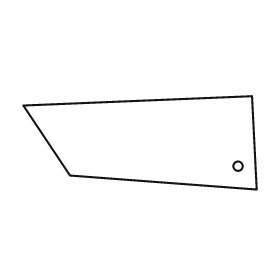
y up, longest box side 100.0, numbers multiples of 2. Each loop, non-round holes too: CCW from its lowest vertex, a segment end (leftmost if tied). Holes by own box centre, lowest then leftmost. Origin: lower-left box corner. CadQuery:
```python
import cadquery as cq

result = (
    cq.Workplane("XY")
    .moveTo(100.0, 0.0)
    .lineTo(98.0, 40.0)
    .lineTo(0.0, 36.0)
    .lineTo(20.0, 6.0)
    .close()
    .moveTo(92.0, 10.0)
    .circle(2.0)
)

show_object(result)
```